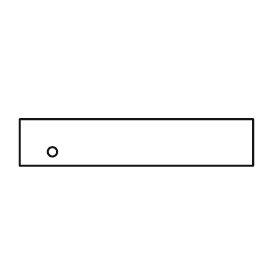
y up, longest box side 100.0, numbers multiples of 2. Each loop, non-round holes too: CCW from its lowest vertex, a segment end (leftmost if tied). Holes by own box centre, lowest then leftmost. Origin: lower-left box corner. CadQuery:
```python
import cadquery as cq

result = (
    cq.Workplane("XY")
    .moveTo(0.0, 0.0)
    .lineTo(100.0, 0.0)
    .lineTo(100.0, 20.0)
    .lineTo(0.0, 20.0)
    .close()
    .moveTo(14.0, 6.0)
    .circle(2.0)
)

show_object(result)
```